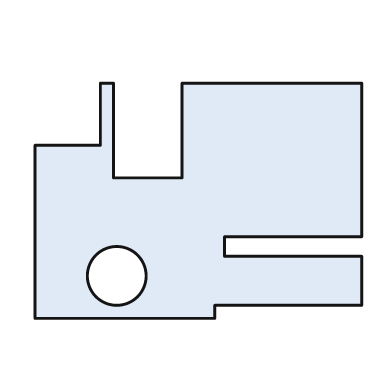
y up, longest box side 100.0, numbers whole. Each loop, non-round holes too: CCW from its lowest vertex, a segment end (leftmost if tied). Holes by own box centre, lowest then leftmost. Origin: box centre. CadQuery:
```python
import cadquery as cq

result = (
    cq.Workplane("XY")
    .moveTo(-50.0, -36.0)
    .lineTo(5.0, -36.0)
    .lineTo(5.0, -32.0)
    .lineTo(50.0, -32.0)
    .lineTo(50.0, -17.0)
    .lineTo(8.0, -17.0)
    .lineTo(8.0, -11.0)
    .lineTo(50.0, -11.0)
    .lineTo(50.0, 36.0)
    .lineTo(-5.0, 36.0)
    .lineTo(-5.0, 7.0)
    .lineTo(-26.0, 7.0)
    .lineTo(-26.0, 36.0)
    .lineTo(-30.0, 36.0)
    .lineTo(-30.0, 17.0)
    .lineTo(-50.0, 17.0)
    .close()
    .moveTo(-25.0, -23.0)
    .circle(9.0)
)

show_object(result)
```